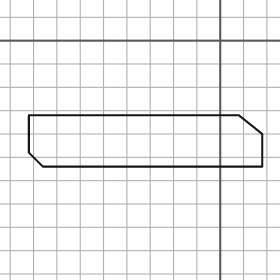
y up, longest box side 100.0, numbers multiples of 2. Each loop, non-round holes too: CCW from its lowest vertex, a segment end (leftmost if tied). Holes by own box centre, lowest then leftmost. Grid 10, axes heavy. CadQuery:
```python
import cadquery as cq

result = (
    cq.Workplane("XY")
    .moveTo(-76.0, -54.0)
    .lineTo(18.0, -54.0)
    .lineTo(18.0, -40.0)
    .lineTo(8.0, -32.0)
    .lineTo(-82.0, -32.0)
    .lineTo(-82.0, -48.0)
    .close()
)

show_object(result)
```